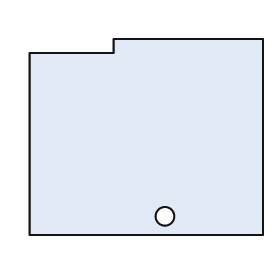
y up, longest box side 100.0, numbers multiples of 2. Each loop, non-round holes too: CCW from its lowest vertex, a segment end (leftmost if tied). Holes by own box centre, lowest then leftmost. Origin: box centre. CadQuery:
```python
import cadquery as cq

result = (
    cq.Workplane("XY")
    .moveTo(-50.0, -42.0)
    .lineTo(50.0, -42.0)
    .lineTo(50.0, 42.0)
    .lineTo(-14.0, 42.0)
    .lineTo(-14.0, 36.0)
    .lineTo(-50.0, 36.0)
    .close()
    .moveTo(8.0, -34.0)
    .circle(4.0)
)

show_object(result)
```